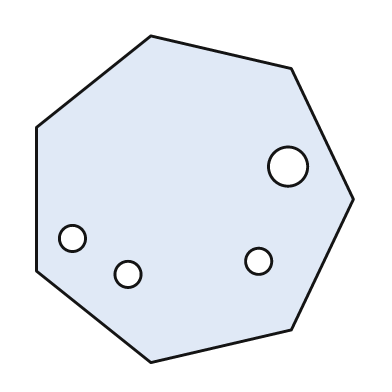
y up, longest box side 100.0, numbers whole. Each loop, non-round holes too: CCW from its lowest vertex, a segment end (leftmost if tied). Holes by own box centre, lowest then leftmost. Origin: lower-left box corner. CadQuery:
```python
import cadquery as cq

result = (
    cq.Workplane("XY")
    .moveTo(35.0, 0.0)
    .lineTo(78.0, 10.0)
    .lineTo(97.0, 50.0)
    .lineTo(78.0, 90.0)
    .lineTo(35.0, 100.0)
    .lineTo(0.0, 72.0)
    .lineTo(0.0, 28.0)
    .close()
    .moveTo(28.0, 27.0)
    .circle(4.0)
    .moveTo(68.0, 31.0)
    .circle(4.0)
    .moveTo(11.0, 38.0)
    .circle(4.0)
    .moveTo(77.0, 60.0)
    .circle(6.0)
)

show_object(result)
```